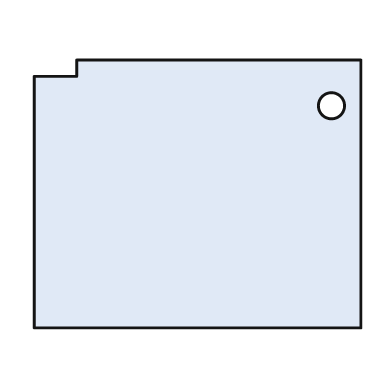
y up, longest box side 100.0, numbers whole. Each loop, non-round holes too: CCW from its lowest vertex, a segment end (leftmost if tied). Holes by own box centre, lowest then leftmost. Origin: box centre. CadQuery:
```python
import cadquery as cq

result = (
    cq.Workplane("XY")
    .moveTo(-50.0, -41.0)
    .lineTo(50.0, -41.0)
    .lineTo(50.0, 41.0)
    .lineTo(-37.0, 41.0)
    .lineTo(-37.0, 36.0)
    .lineTo(-50.0, 36.0)
    .close()
    .moveTo(41.0, 27.0)
    .circle(4.0)
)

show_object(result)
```